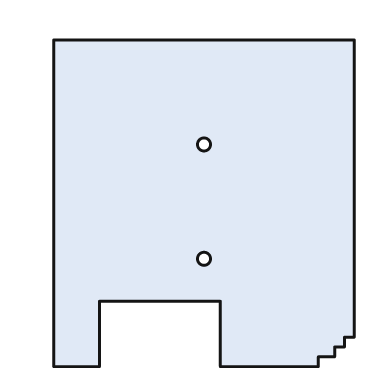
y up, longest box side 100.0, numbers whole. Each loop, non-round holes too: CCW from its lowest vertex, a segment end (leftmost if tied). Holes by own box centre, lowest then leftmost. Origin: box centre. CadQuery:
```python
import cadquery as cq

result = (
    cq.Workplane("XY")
    .moveTo(-46.0, -50.0)
    .lineTo(-32.0, -50.0)
    .lineTo(-32.0, -30.0)
    .lineTo(5.0, -30.0)
    .lineTo(5.0, -50.0)
    .lineTo(35.0, -50.0)
    .lineTo(35.0, -47.0)
    .lineTo(40.0, -47.0)
    .lineTo(40.0, -44.0)
    .lineTo(43.0, -44.0)
    .lineTo(43.0, -41.0)
    .lineTo(46.0, -41.0)
    .lineTo(46.0, 50.0)
    .lineTo(-46.0, 50.0)
    .close()
    .moveTo(0.0, -17.0)
    .circle(2.0)
    .moveTo(0.0, 18.0)
    .circle(2.0)
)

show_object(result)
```